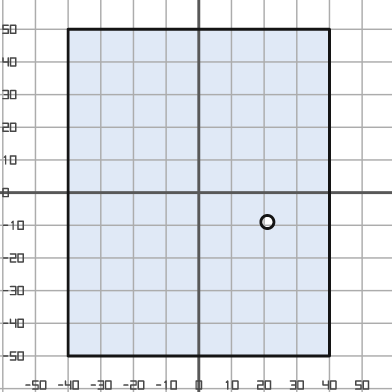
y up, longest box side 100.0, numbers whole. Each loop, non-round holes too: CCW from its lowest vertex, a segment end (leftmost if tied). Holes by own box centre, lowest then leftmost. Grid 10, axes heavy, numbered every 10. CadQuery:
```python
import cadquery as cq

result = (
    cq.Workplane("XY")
    .moveTo(-40.0, -50.0)
    .lineTo(40.0, -50.0)
    .lineTo(40.0, 50.0)
    .lineTo(-40.0, 50.0)
    .close()
    .moveTo(21.0, -9.0)
    .circle(2.0)
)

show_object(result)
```